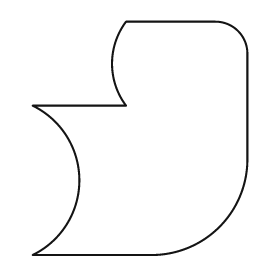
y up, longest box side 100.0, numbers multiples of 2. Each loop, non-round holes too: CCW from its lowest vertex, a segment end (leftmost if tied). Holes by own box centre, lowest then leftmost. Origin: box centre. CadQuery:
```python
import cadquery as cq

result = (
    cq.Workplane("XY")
    .moveTo(-46.0, -50.0)
    .lineTo(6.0, -50.0)
    .threePointArc((34.0, -38.0), (46.0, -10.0))
    .lineTo(46.0, 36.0)
    .threePointArc((42.0, 46.0), (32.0, 50.0))
    .lineTo(-6.0, 50.0)
    .threePointArc((-12.0, 32.0), (-6.0, 14.0))
    .lineTo(-46.0, 14.0)
    .threePointArc((-26.0, -18.0), (-46.0, -50.0))
    .close()
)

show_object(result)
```